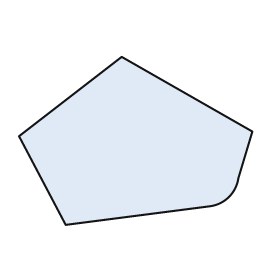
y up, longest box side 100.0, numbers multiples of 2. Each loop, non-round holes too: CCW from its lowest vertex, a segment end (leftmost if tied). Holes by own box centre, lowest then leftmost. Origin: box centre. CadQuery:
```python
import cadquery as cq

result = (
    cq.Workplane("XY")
    .moveTo(-30.0, -36.0)
    .lineTo(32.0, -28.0)
    .threePointArc((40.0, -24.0), (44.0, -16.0))
    .lineTo(50.0, 4.0)
    .lineTo(-6.0, 36.0)
    .lineTo(-50.0, 2.0)
    .close()
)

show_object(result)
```